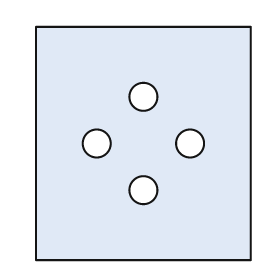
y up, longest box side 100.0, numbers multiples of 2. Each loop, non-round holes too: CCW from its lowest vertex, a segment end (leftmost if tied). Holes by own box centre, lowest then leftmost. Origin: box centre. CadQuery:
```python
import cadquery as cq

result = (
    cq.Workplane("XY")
    .moveTo(-46.0, -50.0)
    .lineTo(46.0, -50.0)
    .lineTo(46.0, 50.0)
    .lineTo(-46.0, 50.0)
    .close()
    .moveTo(0.0, -20.0)
    .circle(6.0)
    .moveTo(-20.0, 0.0)
    .circle(6.0)
    .moveTo(20.0, 0.0)
    .circle(6.0)
    .moveTo(0.0, 20.0)
    .circle(6.0)
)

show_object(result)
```